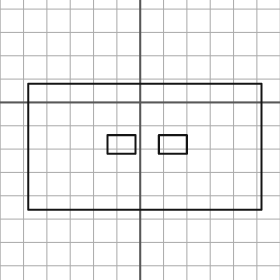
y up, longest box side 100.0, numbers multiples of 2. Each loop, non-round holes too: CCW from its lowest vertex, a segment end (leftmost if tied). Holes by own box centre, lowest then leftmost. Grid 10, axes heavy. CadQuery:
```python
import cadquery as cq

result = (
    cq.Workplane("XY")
    .moveTo(-48.0, -46.0)
    .lineTo(52.0, -46.0)
    .lineTo(52.0, 8.0)
    .lineTo(-48.0, 8.0)
    .close()
    .moveTo(-14.0, -22.0)
    .lineTo(-2.0, -22.0)
    .lineTo(-2.0, -14.0)
    .lineTo(-14.0, -14.0)
    .close()
    .moveTo(8.0, -22.0)
    .lineTo(20.0, -22.0)
    .lineTo(20.0, -14.0)
    .lineTo(8.0, -14.0)
    .close()
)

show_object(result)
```